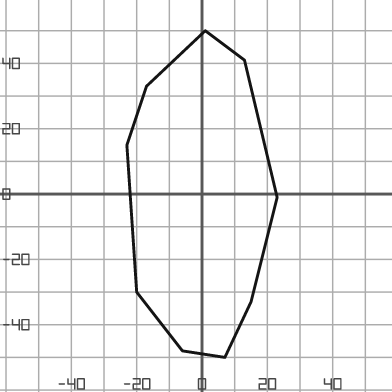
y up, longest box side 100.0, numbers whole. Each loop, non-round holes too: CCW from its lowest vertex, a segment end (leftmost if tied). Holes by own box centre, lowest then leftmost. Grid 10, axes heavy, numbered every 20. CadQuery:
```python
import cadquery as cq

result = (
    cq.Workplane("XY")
    .moveTo(7.0, -50.0)
    .lineTo(15.0, -33.0)
    .lineTo(23.0, -1.0)
    .lineTo(13.0, 41.0)
    .lineTo(1.0, 50.0)
    .lineTo(-17.0, 33.0)
    .lineTo(-23.0, 15.0)
    .lineTo(-20.0, -30.0)
    .lineTo(-6.0, -48.0)
    .close()
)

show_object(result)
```